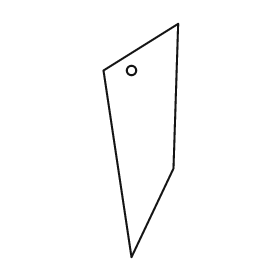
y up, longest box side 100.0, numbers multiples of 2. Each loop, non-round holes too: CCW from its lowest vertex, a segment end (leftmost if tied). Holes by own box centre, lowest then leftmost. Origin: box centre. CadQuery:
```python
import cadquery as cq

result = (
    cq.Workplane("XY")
    .moveTo(-4.0, -50.0)
    .lineTo(14.0, -12.0)
    .lineTo(16.0, 50.0)
    .lineTo(-16.0, 30.0)
    .close()
    .moveTo(-4.0, 30.0)
    .circle(2.0)
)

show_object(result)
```